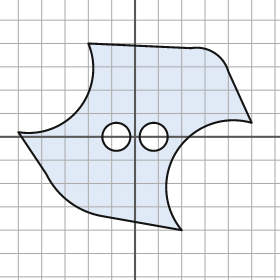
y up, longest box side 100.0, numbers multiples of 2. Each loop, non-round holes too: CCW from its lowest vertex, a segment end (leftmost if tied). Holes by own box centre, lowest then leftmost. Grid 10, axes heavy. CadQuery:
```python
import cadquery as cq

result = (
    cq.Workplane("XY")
    .moveTo(20.0, -40.0)
    .threePointArc((18.0, -6.0), (50.0, 6.0))
    .lineTo(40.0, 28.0)
    .threePointArc((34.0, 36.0), (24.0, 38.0))
    .lineTo(-20.0, 40.0)
    .threePointArc((-24.0, 12.0), (-50.0, 2.0))
    .lineTo(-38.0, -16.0)
    .threePointArc((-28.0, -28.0), (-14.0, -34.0))
    .close()
    .moveTo(-8.0, 0.0)
    .circle(6.0)
    .moveTo(8.0, 0.0)
    .circle(6.0)
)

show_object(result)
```